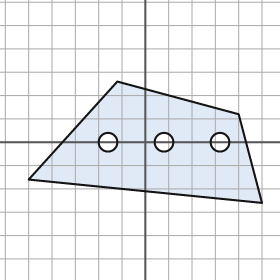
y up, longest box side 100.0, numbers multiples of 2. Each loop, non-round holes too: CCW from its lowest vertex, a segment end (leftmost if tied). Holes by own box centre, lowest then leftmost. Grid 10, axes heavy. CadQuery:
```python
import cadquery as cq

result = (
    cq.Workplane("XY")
    .moveTo(50.0, -26.0)
    .lineTo(40.0, 12.0)
    .lineTo(-12.0, 26.0)
    .lineTo(-50.0, -16.0)
    .close()
    .moveTo(-16.0, 0.0)
    .circle(4.0)
    .moveTo(8.0, 0.0)
    .circle(4.0)
    .moveTo(32.0, 0.0)
    .circle(4.0)
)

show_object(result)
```